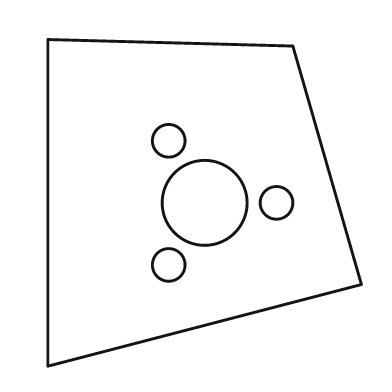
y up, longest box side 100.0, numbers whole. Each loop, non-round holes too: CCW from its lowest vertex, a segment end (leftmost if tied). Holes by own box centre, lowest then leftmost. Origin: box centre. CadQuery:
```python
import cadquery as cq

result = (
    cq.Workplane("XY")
    .moveTo(-48.0, -50.0)
    .lineTo(48.0, -25.0)
    .lineTo(27.0, 48.0)
    .lineTo(-48.0, 50.0)
    .close()
    .moveTo(-11.0, -19.0)
    .circle(5.0)
    .moveTo(0.0, 0.0)
    .circle(13.0)
    .moveTo(22.0, 0.0)
    .circle(5.0)
    .moveTo(-11.0, 19.0)
    .circle(5.0)
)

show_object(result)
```